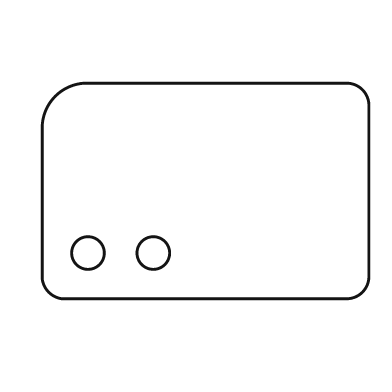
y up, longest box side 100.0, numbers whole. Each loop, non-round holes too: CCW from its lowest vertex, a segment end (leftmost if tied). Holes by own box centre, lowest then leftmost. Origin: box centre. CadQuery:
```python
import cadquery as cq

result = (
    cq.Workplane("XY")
    .moveTo(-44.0, -33.0)
    .lineTo(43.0, -33.0)
    .threePointArc((48.0, -31.0), (50.0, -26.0))
    .lineTo(50.0, 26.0)
    .threePointArc((48.0, 31.0), (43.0, 33.0))
    .lineTo(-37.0, 33.0)
    .threePointArc((-46.0, 29.0), (-50.0, 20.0))
    .lineTo(-50.0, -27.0)
    .threePointArc((-48.0, -31.0), (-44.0, -33.0))
    .close()
    .moveTo(-36.0, -19.0)
    .circle(5.0)
    .moveTo(-16.0, -19.0)
    .circle(5.0)
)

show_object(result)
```